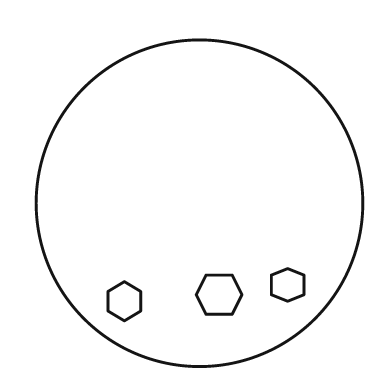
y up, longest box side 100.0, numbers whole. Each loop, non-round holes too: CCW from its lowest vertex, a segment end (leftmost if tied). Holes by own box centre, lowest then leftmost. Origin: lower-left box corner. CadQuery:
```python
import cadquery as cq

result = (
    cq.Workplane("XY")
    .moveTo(50.0, 50.0)
    .circle(50.0)
    .moveTo(27.0, 14.0)
    .lineTo(32.0, 17.0)
    .lineTo(32.0, 23.0)
    .lineTo(27.0, 26.0)
    .lineTo(22.0, 23.0)
    .lineTo(22.0, 17.0)
    .close()
    .moveTo(52.0, 16.0)
    .lineTo(60.0, 16.0)
    .lineTo(63.0, 22.0)
    .lineTo(60.0, 28.0)
    .lineTo(52.0, 28.0)
    .lineTo(49.0, 22.0)
    .close()
    .moveTo(77.0, 20.0)
    .lineTo(82.0, 22.0)
    .lineTo(82.0, 28.0)
    .lineTo(77.0, 30.0)
    .lineTo(72.0, 28.0)
    .lineTo(72.0, 22.0)
    .close()
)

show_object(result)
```